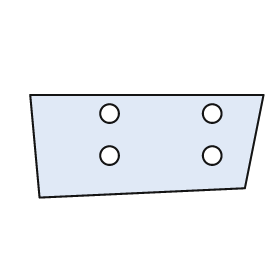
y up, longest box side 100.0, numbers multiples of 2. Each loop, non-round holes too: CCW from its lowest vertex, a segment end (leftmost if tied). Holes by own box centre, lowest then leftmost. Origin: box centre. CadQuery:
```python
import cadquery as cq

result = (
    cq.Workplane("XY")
    .moveTo(-46.0, -22.0)
    .lineTo(42.0, -18.0)
    .lineTo(50.0, 22.0)
    .lineTo(-50.0, 22.0)
    .close()
    .moveTo(-16.0, -4.0)
    .circle(4.0)
    .moveTo(28.0, -4.0)
    .circle(4.0)
    .moveTo(-16.0, 14.0)
    .circle(4.0)
    .moveTo(28.0, 14.0)
    .circle(4.0)
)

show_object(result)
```